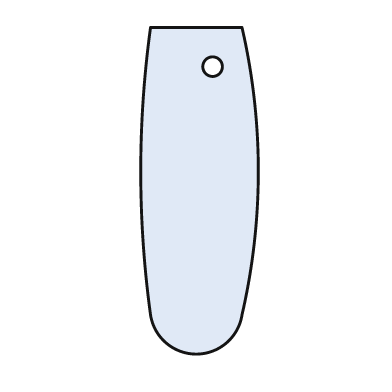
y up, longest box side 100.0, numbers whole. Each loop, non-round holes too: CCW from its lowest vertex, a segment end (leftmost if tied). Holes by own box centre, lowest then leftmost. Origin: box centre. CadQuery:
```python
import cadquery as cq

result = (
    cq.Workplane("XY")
    .moveTo(-15.0, -38.0)
    .threePointArc((-1.0, -50.0), (13.0, -38.0))
    .threePointArc((18.0, 6.0), (13.0, 50.0))
    .lineTo(-15.0, 50.0)
    .threePointArc((-18.0, 6.0), (-15.0, -38.0))
    .close()
    .moveTo(4.0, 38.0)
    .circle(3.0)
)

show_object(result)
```